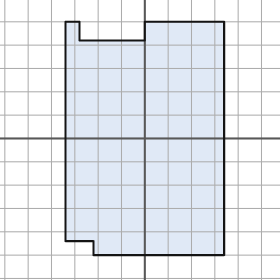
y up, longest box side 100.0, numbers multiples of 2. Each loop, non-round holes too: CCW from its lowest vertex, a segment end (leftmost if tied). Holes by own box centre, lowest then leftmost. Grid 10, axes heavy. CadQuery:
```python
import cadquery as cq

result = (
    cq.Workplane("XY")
    .moveTo(-22.0, -50.0)
    .lineTo(34.0, -50.0)
    .lineTo(34.0, 50.0)
    .lineTo(0.0, 50.0)
    .lineTo(0.0, 42.0)
    .lineTo(-28.0, 42.0)
    .lineTo(-28.0, 50.0)
    .lineTo(-34.0, 50.0)
    .lineTo(-34.0, -44.0)
    .lineTo(-22.0, -44.0)
    .close()
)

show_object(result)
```